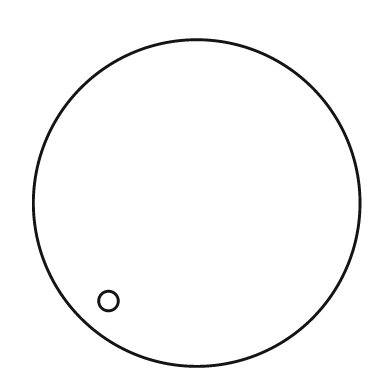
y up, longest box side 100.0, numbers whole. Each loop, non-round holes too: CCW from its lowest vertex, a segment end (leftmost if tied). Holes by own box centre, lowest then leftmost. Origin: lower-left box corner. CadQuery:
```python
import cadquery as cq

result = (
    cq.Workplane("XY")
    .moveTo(50.0, 50.0)
    .circle(50.0)
    .moveTo(23.0, 20.0)
    .circle(3.0)
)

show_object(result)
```